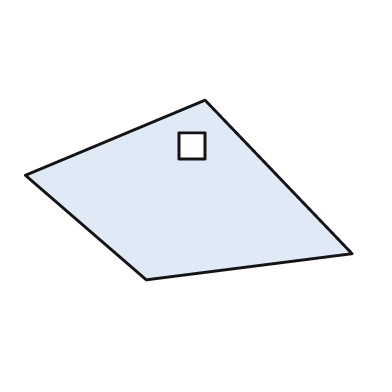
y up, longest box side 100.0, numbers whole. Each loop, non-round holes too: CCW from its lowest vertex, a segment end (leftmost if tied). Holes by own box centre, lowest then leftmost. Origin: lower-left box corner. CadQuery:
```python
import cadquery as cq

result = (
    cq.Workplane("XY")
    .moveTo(37.0, 0.0)
    .lineTo(100.0, 8.0)
    .lineTo(55.0, 55.0)
    .lineTo(0.0, 32.0)
    .close()
    .moveTo(47.0, 37.0)
    .lineTo(55.0, 37.0)
    .lineTo(55.0, 45.0)
    .lineTo(47.0, 45.0)
    .close()
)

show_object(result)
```